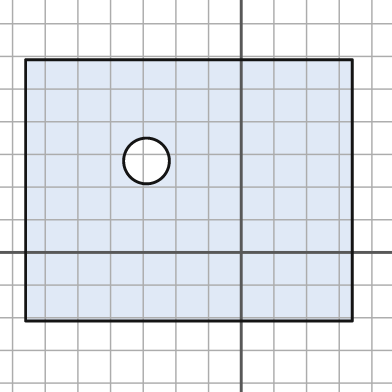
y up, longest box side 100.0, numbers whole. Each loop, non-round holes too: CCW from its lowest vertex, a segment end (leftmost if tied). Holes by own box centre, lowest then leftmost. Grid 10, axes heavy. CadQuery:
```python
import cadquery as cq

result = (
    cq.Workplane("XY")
    .moveTo(-66.0, -21.0)
    .lineTo(34.0, -21.0)
    .lineTo(34.0, 59.0)
    .lineTo(-66.0, 59.0)
    .close()
    .moveTo(-29.0, 28.0)
    .circle(7.0)
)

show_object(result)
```